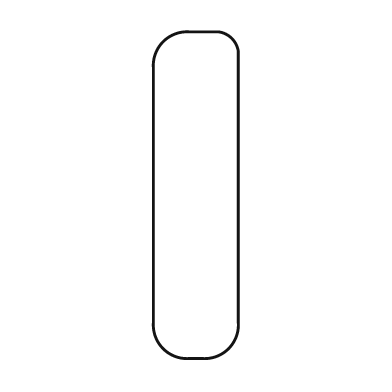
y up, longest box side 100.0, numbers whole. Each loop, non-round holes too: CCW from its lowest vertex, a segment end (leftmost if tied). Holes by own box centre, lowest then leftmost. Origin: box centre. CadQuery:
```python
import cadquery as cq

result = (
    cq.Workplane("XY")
    .moveTo(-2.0, -50.0)
    .lineTo(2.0, -50.0)
    .threePointArc((10.0, -47.0), (13.0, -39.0))
    .lineTo(13.0, 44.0)
    .threePointArc((11.0, 48.0), (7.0, 50.0))
    .lineTo(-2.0, 50.0)
    .threePointArc((-10.0, 47.0), (-13.0, 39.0))
    .lineTo(-13.0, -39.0)
    .threePointArc((-10.0, -47.0), (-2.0, -50.0))
    .close()
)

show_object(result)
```